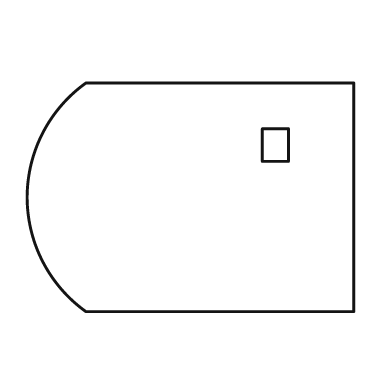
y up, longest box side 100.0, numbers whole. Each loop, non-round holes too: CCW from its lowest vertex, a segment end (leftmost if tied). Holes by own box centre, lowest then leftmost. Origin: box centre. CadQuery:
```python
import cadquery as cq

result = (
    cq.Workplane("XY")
    .moveTo(-32.0, -35.0)
    .lineTo(50.0, -35.0)
    .lineTo(50.0, 35.0)
    .lineTo(-32.0, 35.0)
    .threePointArc((-50.0, 0.0), (-32.0, -35.0))
    .close()
    .moveTo(22.0, 11.0)
    .lineTo(30.0, 11.0)
    .lineTo(30.0, 21.0)
    .lineTo(22.0, 21.0)
    .close()
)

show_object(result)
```